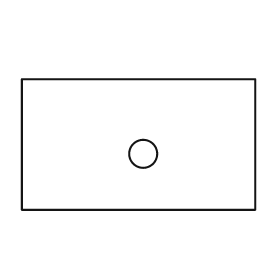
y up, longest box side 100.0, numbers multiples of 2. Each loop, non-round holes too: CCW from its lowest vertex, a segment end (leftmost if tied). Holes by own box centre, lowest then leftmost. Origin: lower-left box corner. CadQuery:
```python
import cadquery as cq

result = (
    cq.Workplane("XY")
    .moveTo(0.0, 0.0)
    .lineTo(100.0, 0.0)
    .lineTo(100.0, 56.0)
    .lineTo(0.0, 56.0)
    .close()
    .moveTo(52.0, 24.0)
    .circle(6.0)
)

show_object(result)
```